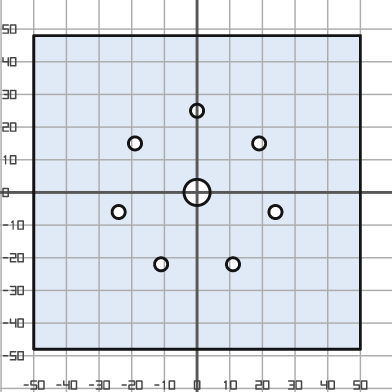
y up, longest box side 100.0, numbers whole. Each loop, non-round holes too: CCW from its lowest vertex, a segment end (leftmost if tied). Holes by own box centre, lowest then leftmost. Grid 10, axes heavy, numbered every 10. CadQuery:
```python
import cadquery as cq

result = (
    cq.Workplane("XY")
    .moveTo(-50.0, -48.0)
    .lineTo(50.0, -48.0)
    .lineTo(50.0, 48.0)
    .lineTo(-50.0, 48.0)
    .close()
    .moveTo(-11.0, -22.0)
    .circle(2.0)
    .moveTo(11.0, -22.0)
    .circle(2.0)
    .moveTo(-24.0, -6.0)
    .circle(2.0)
    .moveTo(24.0, -6.0)
    .circle(2.0)
    .moveTo(0.0, 0.0)
    .circle(4.0)
    .moveTo(-19.0, 15.0)
    .circle(2.0)
    .moveTo(19.0, 15.0)
    .circle(2.0)
    .moveTo(0.0, 25.0)
    .circle(2.0)
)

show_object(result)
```